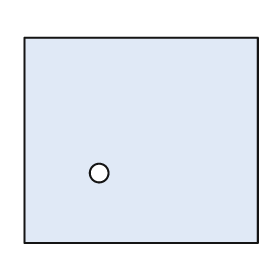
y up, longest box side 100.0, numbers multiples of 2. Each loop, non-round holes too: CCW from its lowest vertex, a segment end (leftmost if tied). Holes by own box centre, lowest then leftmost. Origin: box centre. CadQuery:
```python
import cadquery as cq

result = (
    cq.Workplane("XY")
    .moveTo(-50.0, -44.0)
    .lineTo(50.0, -44.0)
    .lineTo(50.0, 44.0)
    .lineTo(-50.0, 44.0)
    .close()
    .moveTo(-18.0, -14.0)
    .circle(4.0)
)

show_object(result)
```